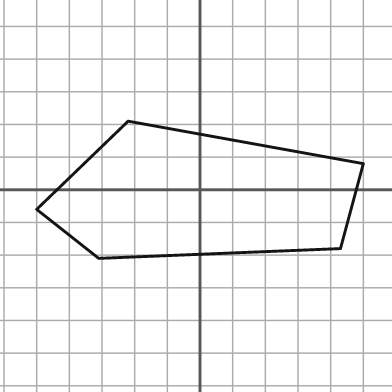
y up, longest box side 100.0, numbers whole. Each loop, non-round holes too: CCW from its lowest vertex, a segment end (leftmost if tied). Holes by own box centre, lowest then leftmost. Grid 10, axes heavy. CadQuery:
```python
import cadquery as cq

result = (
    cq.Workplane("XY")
    .moveTo(-31.0, -21.0)
    .lineTo(43.0, -18.0)
    .lineTo(50.0, 8.0)
    .lineTo(-22.0, 21.0)
    .lineTo(-50.0, -6.0)
    .close()
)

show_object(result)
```